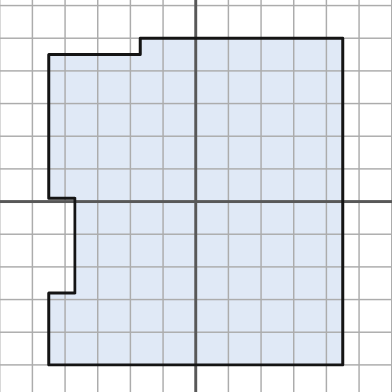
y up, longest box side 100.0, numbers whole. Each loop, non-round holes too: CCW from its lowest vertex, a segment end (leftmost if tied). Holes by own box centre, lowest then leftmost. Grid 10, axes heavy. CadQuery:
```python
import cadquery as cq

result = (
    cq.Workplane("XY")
    .moveTo(-45.0, -50.0)
    .lineTo(45.0, -50.0)
    .lineTo(45.0, 50.0)
    .lineTo(-17.0, 50.0)
    .lineTo(-17.0, 45.0)
    .lineTo(-45.0, 45.0)
    .lineTo(-45.0, 1.0)
    .lineTo(-37.0, 1.0)
    .lineTo(-37.0, -28.0)
    .lineTo(-45.0, -28.0)
    .close()
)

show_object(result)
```